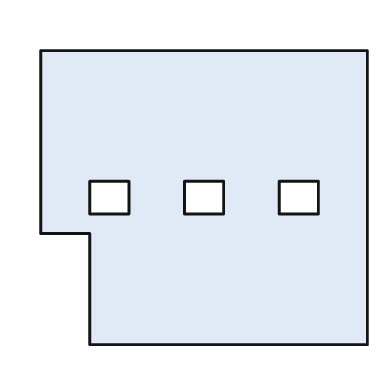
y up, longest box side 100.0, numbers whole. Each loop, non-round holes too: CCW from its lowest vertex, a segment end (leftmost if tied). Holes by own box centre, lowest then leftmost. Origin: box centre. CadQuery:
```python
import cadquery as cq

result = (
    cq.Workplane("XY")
    .moveTo(-35.0, -45.0)
    .lineTo(50.0, -45.0)
    .lineTo(50.0, 45.0)
    .lineTo(-50.0, 45.0)
    .lineTo(-50.0, -11.0)
    .lineTo(-35.0, -11.0)
    .close()
    .moveTo(-35.0, -5.0)
    .lineTo(-23.0, -5.0)
    .lineTo(-23.0, 5.0)
    .lineTo(-35.0, 5.0)
    .close()
    .moveTo(-6.0, -5.0)
    .lineTo(6.0, -5.0)
    .lineTo(6.0, 5.0)
    .lineTo(-6.0, 5.0)
    .close()
    .moveTo(23.0, -5.0)
    .lineTo(35.0, -5.0)
    .lineTo(35.0, 5.0)
    .lineTo(23.0, 5.0)
    .close()
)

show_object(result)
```